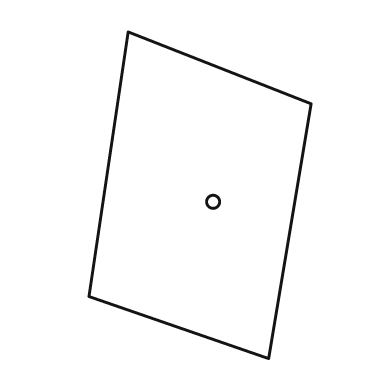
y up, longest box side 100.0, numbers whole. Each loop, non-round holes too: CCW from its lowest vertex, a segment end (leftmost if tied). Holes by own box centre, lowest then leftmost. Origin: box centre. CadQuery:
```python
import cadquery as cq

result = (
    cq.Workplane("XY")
    .moveTo(21.0, -50.0)
    .lineTo(34.0, 28.0)
    .lineTo(-22.0, 50.0)
    .lineTo(-34.0, -31.0)
    .close()
    .moveTo(4.0, -2.0)
    .circle(2.0)
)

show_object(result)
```